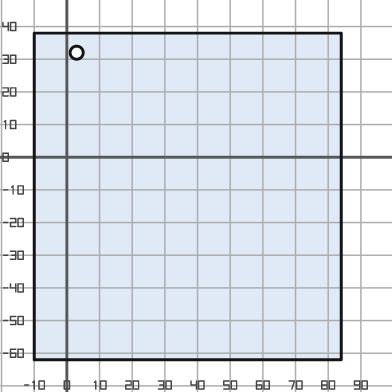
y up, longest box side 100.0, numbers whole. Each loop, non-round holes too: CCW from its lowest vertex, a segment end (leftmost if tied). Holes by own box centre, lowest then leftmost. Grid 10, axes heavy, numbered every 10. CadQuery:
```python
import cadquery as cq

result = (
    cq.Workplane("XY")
    .moveTo(-10.0, -62.0)
    .lineTo(84.0, -62.0)
    .lineTo(84.0, 38.0)
    .lineTo(-10.0, 38.0)
    .close()
    .moveTo(3.0, 32.0)
    .circle(2.0)
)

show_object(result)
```